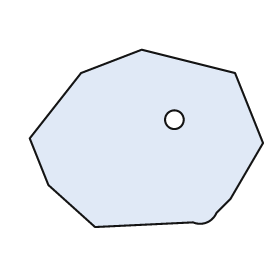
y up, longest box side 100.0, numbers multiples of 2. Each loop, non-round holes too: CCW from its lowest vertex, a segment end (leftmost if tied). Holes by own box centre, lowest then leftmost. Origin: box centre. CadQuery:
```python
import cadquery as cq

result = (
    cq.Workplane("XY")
    .moveTo(-22.0, -38.0)
    .lineTo(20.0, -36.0)
    .threePointArc((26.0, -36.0), (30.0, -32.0))
    .lineTo(36.0, -26.0)
    .lineTo(50.0, -2.0)
    .lineTo(38.0, 28.0)
    .lineTo(-2.0, 38.0)
    .lineTo(-28.0, 28.0)
    .lineTo(-50.0, 0.0)
    .lineTo(-42.0, -20.0)
    .close()
    .moveTo(12.0, 8.0)
    .circle(4.0)
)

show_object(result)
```